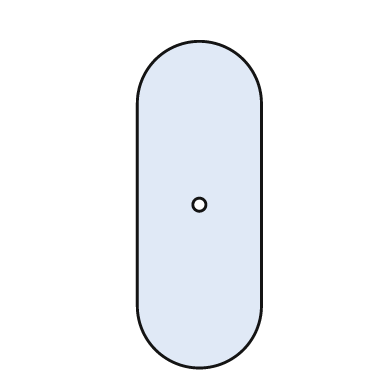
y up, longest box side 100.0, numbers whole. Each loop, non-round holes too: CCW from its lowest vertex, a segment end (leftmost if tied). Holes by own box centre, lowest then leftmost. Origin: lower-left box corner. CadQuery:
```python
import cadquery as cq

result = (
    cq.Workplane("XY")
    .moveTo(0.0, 19.0)
    .threePointArc((19.0, 0.0), (38.0, 19.0))
    .lineTo(38.0, 81.0)
    .threePointArc((19.0, 100.0), (0.0, 81.0))
    .close()
    .moveTo(19.0, 50.0)
    .circle(2.0)
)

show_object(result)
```